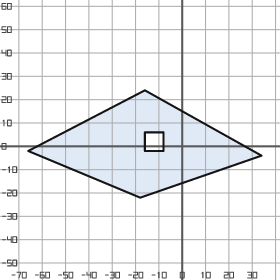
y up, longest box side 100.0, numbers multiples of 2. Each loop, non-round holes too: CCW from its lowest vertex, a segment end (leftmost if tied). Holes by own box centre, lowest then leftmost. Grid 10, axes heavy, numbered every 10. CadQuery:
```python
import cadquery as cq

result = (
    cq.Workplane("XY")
    .moveTo(-18.0, -22.0)
    .lineTo(34.0, -4.0)
    .lineTo(-16.0, 24.0)
    .lineTo(-66.0, -2.0)
    .close()
    .moveTo(-16.0, -2.0)
    .lineTo(-8.0, -2.0)
    .lineTo(-8.0, 6.0)
    .lineTo(-16.0, 6.0)
    .close()
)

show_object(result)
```